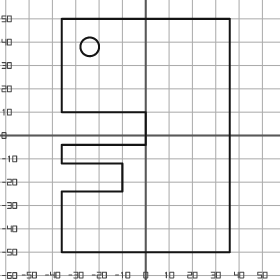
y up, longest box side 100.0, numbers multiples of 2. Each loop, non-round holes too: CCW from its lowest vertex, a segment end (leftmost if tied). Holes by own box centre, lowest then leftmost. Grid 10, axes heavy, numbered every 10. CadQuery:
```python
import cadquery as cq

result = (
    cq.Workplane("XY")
    .moveTo(-36.0, -50.0)
    .lineTo(36.0, -50.0)
    .lineTo(36.0, 50.0)
    .lineTo(-36.0, 50.0)
    .lineTo(-36.0, 10.0)
    .lineTo(0.0, 10.0)
    .lineTo(0.0, -4.0)
    .lineTo(-36.0, -4.0)
    .lineTo(-36.0, -12.0)
    .lineTo(-10.0, -12.0)
    .lineTo(-10.0, -24.0)
    .lineTo(-36.0, -24.0)
    .close()
    .moveTo(-24.0, 38.0)
    .circle(4.0)
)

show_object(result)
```